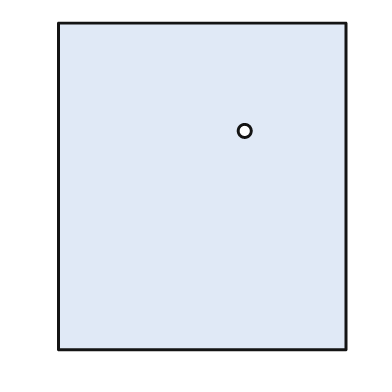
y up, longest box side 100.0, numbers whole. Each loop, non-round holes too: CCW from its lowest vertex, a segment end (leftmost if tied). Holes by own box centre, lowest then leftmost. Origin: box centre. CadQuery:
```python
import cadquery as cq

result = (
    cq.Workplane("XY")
    .moveTo(-44.0, -50.0)
    .lineTo(44.0, -50.0)
    .lineTo(44.0, 50.0)
    .lineTo(-44.0, 50.0)
    .close()
    .moveTo(13.0, 17.0)
    .circle(2.0)
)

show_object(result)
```